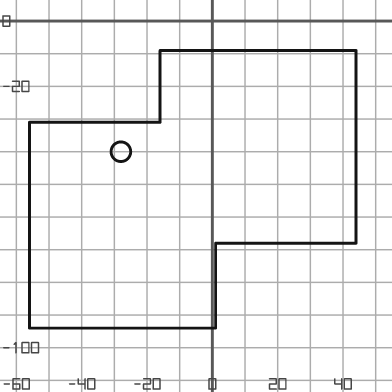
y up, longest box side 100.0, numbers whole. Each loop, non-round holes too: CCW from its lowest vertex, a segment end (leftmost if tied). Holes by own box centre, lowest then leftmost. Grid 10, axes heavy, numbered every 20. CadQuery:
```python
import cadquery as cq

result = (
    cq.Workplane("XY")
    .moveTo(-56.0, -94.0)
    .lineTo(1.0, -94.0)
    .lineTo(1.0, -68.0)
    .lineTo(44.0, -68.0)
    .lineTo(44.0, -9.0)
    .lineTo(-16.0, -9.0)
    .lineTo(-16.0, -31.0)
    .lineTo(-56.0, -31.0)
    .close()
    .moveTo(-28.0, -40.0)
    .circle(3.0)
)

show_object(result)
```